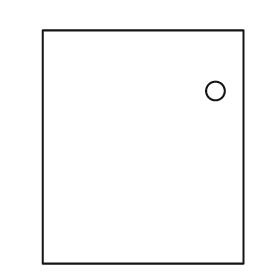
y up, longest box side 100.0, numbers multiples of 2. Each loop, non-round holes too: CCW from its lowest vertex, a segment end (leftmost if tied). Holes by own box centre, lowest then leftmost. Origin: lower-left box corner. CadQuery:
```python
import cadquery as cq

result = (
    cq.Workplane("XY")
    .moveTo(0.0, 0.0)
    .lineTo(86.0, 0.0)
    .lineTo(86.0, 100.0)
    .lineTo(0.0, 100.0)
    .close()
    .moveTo(74.0, 74.0)
    .circle(4.0)
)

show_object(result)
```